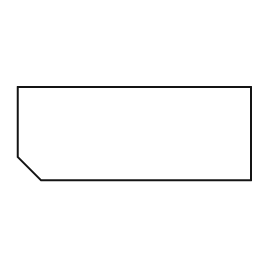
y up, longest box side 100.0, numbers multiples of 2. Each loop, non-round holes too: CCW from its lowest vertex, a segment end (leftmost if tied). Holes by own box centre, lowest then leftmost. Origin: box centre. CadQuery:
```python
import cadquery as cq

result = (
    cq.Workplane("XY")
    .moveTo(-40.0, -20.0)
    .lineTo(50.0, -20.0)
    .lineTo(50.0, 20.0)
    .lineTo(-50.0, 20.0)
    .lineTo(-50.0, -10.0)
    .close()
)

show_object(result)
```